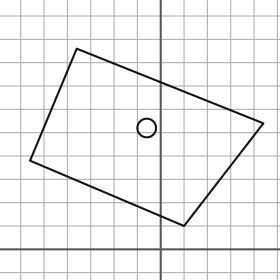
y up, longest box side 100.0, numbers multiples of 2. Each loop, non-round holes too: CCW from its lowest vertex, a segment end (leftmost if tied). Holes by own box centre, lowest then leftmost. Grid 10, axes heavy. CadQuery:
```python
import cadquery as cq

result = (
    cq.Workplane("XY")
    .moveTo(10.0, 10.0)
    .lineTo(44.0, 54.0)
    .lineTo(-36.0, 86.0)
    .lineTo(-56.0, 38.0)
    .close()
    .moveTo(-6.0, 52.0)
    .circle(4.0)
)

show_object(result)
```